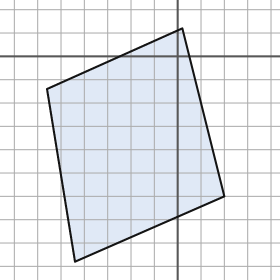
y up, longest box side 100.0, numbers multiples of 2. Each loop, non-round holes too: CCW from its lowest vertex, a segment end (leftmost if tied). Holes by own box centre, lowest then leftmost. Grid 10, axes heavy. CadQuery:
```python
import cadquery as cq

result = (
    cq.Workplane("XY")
    .moveTo(-44.0, -88.0)
    .lineTo(20.0, -60.0)
    .lineTo(2.0, 12.0)
    .lineTo(-56.0, -14.0)
    .close()
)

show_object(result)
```